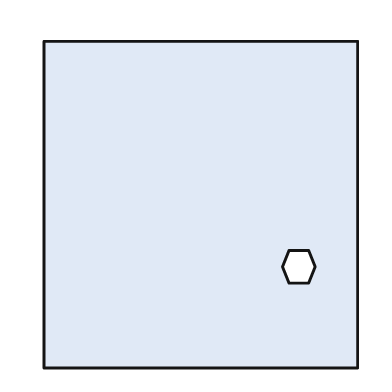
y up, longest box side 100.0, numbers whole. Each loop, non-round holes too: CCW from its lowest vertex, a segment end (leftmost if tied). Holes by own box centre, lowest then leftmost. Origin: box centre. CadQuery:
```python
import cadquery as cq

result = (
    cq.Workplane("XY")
    .moveTo(-48.0, -50.0)
    .lineTo(48.0, -50.0)
    .lineTo(48.0, 50.0)
    .lineTo(-48.0, 50.0)
    .close()
    .moveTo(27.0, -24.0)
    .lineTo(33.0, -24.0)
    .lineTo(35.0, -19.0)
    .lineTo(33.0, -14.0)
    .lineTo(27.0, -14.0)
    .lineTo(25.0, -19.0)
    .close()
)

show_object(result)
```